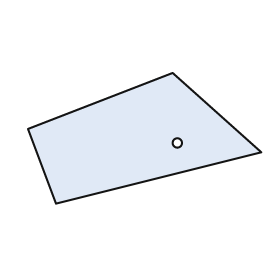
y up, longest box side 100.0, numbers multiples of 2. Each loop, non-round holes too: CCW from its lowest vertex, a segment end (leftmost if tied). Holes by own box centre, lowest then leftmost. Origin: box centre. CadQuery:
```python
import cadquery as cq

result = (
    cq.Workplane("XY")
    .moveTo(-38.0, -28.0)
    .lineTo(50.0, -6.0)
    .lineTo(12.0, 28.0)
    .lineTo(-50.0, 4.0)
    .close()
    .moveTo(14.0, -2.0)
    .circle(2.0)
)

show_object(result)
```